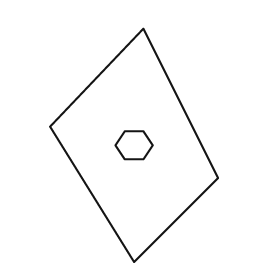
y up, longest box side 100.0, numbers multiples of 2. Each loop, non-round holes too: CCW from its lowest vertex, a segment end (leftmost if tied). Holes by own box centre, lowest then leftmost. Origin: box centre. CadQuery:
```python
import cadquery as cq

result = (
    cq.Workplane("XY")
    .moveTo(0.0, -50.0)
    .lineTo(36.0, -14.0)
    .lineTo(4.0, 50.0)
    .lineTo(-36.0, 8.0)
    .close()
    .moveTo(-4.0, -6.0)
    .lineTo(4.0, -6.0)
    .lineTo(8.0, 0.0)
    .lineTo(4.0, 6.0)
    .lineTo(-4.0, 6.0)
    .lineTo(-8.0, 0.0)
    .close()
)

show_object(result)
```